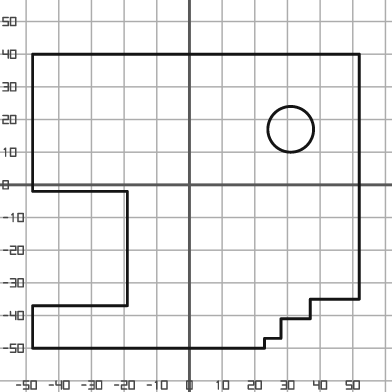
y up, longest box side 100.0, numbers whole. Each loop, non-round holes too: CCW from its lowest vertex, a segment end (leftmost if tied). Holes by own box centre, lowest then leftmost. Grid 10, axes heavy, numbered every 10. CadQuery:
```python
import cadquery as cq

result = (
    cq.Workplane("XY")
    .moveTo(-48.0, -50.0)
    .lineTo(23.0, -50.0)
    .lineTo(23.0, -47.0)
    .lineTo(28.0, -47.0)
    .lineTo(28.0, -41.0)
    .lineTo(37.0, -41.0)
    .lineTo(37.0, -35.0)
    .lineTo(52.0, -35.0)
    .lineTo(52.0, 40.0)
    .lineTo(-48.0, 40.0)
    .lineTo(-48.0, -2.0)
    .lineTo(-19.0, -2.0)
    .lineTo(-19.0, -37.0)
    .lineTo(-48.0, -37.0)
    .close()
    .moveTo(31.0, 17.0)
    .circle(7.0)
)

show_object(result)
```